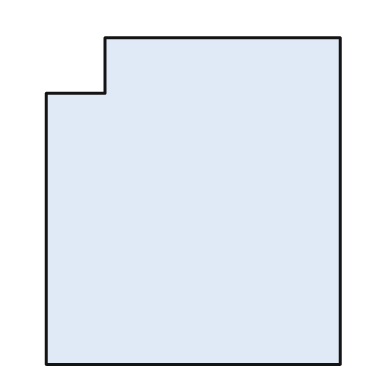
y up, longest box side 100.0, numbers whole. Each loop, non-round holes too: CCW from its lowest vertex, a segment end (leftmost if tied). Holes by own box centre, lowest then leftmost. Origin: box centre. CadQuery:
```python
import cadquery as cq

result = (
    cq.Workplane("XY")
    .moveTo(-45.0, -50.0)
    .lineTo(45.0, -50.0)
    .lineTo(45.0, 50.0)
    .lineTo(-27.0, 50.0)
    .lineTo(-27.0, 33.0)
    .lineTo(-45.0, 33.0)
    .close()
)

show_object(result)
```